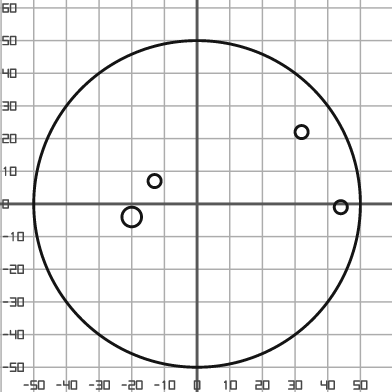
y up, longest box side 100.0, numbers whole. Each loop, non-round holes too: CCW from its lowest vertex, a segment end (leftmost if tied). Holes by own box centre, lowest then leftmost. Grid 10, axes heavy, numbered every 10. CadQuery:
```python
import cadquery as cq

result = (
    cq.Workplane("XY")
    .moveTo(0.0, 0.0)
    .circle(50.0)
    .moveTo(-20.0, -4.0)
    .circle(3.0)
    .moveTo(44.0, -1.0)
    .circle(2.0)
    .moveTo(-13.0, 7.0)
    .circle(2.0)
    .moveTo(32.0, 22.0)
    .circle(2.0)
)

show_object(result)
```